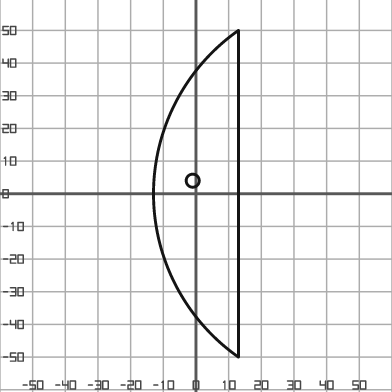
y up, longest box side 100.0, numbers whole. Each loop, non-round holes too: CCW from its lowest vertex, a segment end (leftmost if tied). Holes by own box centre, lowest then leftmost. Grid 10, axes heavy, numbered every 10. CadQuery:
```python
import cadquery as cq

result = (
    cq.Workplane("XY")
    .moveTo(13.0, -50.0)
    .lineTo(13.0, 50.0)
    .threePointArc((-13.0, 0.0), (13.0, -50.0))
    .close()
    .moveTo(-1.0, 4.0)
    .circle(2.0)
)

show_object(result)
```